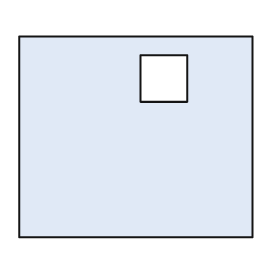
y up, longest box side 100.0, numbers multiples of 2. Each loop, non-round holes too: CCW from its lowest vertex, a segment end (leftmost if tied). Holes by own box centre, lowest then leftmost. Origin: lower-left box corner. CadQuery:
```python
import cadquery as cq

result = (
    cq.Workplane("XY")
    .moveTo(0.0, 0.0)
    .lineTo(100.0, 0.0)
    .lineTo(100.0, 86.0)
    .lineTo(0.0, 86.0)
    .close()
    .moveTo(52.0, 58.0)
    .lineTo(72.0, 58.0)
    .lineTo(72.0, 78.0)
    .lineTo(52.0, 78.0)
    .close()
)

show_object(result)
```